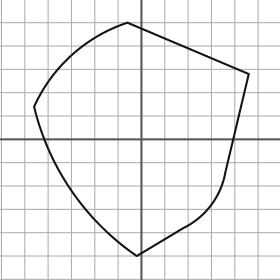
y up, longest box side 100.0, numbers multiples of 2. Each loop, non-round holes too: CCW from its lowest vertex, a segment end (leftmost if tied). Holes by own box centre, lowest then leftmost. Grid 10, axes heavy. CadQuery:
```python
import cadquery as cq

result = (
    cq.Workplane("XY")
    .moveTo(-2.0, -50.0)
    .lineTo(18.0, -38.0)
    .threePointArc((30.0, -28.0), (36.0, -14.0))
    .lineTo(46.0, 28.0)
    .lineTo(-6.0, 50.0)
    .threePointArc((-30.0, 36.0), (-46.0, 14.0))
    .threePointArc((-30.0, -22.0), (-2.0, -50.0))
    .close()
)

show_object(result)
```